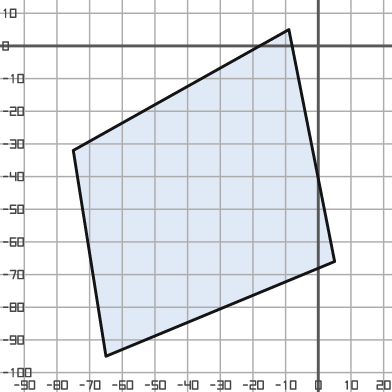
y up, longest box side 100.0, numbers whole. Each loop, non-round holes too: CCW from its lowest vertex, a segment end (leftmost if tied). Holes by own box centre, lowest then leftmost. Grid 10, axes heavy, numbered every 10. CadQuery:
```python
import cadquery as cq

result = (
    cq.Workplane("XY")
    .moveTo(-65.0, -95.0)
    .lineTo(5.0, -66.0)
    .lineTo(-9.0, 5.0)
    .lineTo(-75.0, -32.0)
    .close()
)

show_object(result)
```